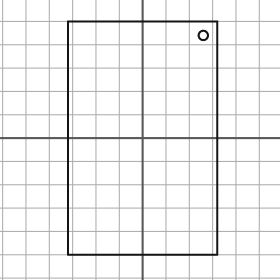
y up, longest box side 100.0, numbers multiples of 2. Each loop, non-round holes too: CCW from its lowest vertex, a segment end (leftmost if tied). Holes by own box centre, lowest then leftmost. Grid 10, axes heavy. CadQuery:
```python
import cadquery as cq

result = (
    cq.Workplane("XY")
    .moveTo(-32.0, -50.0)
    .lineTo(32.0, -50.0)
    .lineTo(32.0, 50.0)
    .lineTo(-32.0, 50.0)
    .close()
    .moveTo(26.0, 44.0)
    .circle(2.0)
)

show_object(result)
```